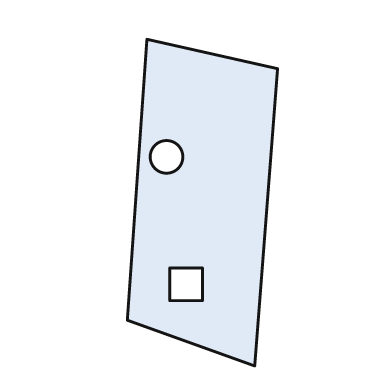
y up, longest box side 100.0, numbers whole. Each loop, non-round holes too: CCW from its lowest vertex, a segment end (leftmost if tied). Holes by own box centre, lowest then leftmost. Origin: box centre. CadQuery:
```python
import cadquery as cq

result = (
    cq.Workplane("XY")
    .moveTo(16.0, -50.0)
    .lineTo(23.0, 41.0)
    .lineTo(-17.0, 50.0)
    .lineTo(-23.0, -36.0)
    .close()
    .moveTo(-10.0, -30.0)
    .lineTo(0.0, -30.0)
    .lineTo(0.0, -20.0)
    .lineTo(-10.0, -20.0)
    .close()
    .moveTo(-11.0, 14.0)
    .circle(5.0)
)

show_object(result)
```